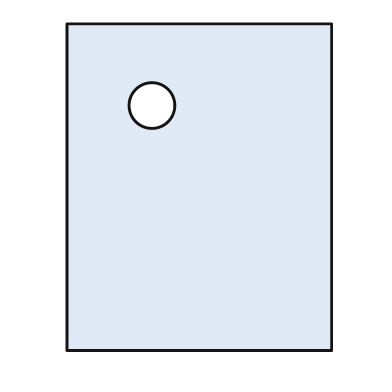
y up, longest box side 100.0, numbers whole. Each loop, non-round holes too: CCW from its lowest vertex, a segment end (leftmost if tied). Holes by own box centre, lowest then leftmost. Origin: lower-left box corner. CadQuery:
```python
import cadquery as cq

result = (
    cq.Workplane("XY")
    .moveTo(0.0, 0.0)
    .lineTo(81.0, 0.0)
    .lineTo(81.0, 100.0)
    .lineTo(0.0, 100.0)
    .close()
    .moveTo(26.0, 75.0)
    .circle(7.0)
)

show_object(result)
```